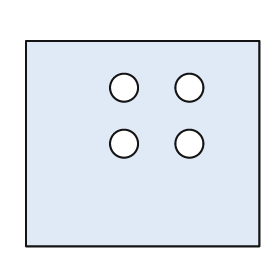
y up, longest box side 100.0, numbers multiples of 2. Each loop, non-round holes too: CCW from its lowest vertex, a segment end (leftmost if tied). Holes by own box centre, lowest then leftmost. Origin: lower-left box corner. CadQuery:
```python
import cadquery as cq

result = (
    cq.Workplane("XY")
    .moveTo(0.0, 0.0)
    .lineTo(100.0, 0.0)
    .lineTo(100.0, 88.0)
    .lineTo(0.0, 88.0)
    .close()
    .moveTo(42.0, 44.0)
    .circle(6.0)
    .moveTo(70.0, 44.0)
    .circle(6.0)
    .moveTo(42.0, 68.0)
    .circle(6.0)
    .moveTo(70.0, 68.0)
    .circle(6.0)
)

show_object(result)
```